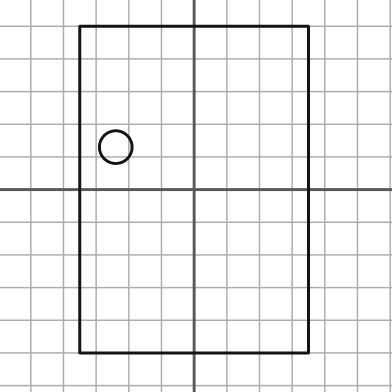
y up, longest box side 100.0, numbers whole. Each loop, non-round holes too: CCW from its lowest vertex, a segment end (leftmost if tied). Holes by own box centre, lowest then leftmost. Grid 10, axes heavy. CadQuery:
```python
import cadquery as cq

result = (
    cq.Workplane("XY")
    .moveTo(-35.0, -50.0)
    .lineTo(35.0, -50.0)
    .lineTo(35.0, 50.0)
    .lineTo(-35.0, 50.0)
    .close()
    .moveTo(-24.0, 13.0)
    .circle(5.0)
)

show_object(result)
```